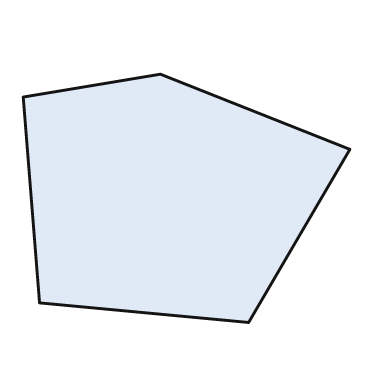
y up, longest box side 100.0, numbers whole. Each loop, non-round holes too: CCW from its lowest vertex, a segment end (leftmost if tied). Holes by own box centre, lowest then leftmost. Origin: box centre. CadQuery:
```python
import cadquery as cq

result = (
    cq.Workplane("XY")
    .moveTo(19.0, -38.0)
    .lineTo(50.0, 15.0)
    .lineTo(-8.0, 38.0)
    .lineTo(-50.0, 31.0)
    .lineTo(-45.0, -32.0)
    .close()
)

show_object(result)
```